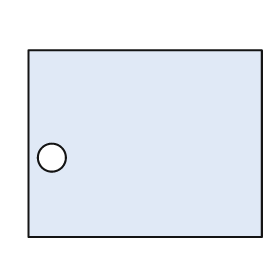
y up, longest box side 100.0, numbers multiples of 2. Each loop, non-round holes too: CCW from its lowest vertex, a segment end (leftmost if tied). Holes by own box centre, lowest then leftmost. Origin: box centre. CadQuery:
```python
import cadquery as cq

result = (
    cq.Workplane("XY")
    .moveTo(-50.0, -40.0)
    .lineTo(50.0, -40.0)
    .lineTo(50.0, 40.0)
    .lineTo(-50.0, 40.0)
    .close()
    .moveTo(-40.0, -6.0)
    .circle(6.0)
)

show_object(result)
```